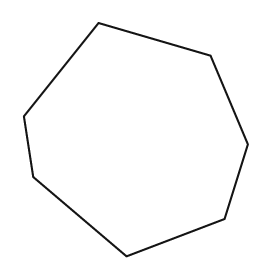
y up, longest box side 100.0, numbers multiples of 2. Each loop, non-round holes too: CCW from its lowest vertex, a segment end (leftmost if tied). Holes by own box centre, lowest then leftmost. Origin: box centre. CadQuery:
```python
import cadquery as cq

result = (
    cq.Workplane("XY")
    .moveTo(-4.0, -50.0)
    .lineTo(38.0, -34.0)
    .lineTo(48.0, -2.0)
    .lineTo(32.0, 36.0)
    .lineTo(-16.0, 50.0)
    .lineTo(-48.0, 10.0)
    .lineTo(-44.0, -16.0)
    .close()
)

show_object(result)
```